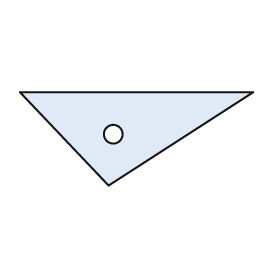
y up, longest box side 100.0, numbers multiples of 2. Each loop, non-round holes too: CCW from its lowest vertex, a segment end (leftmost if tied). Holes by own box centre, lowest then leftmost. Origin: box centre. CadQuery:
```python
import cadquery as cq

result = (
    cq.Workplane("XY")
    .moveTo(-12.0, -20.0)
    .lineTo(50.0, 20.0)
    .lineTo(-50.0, 20.0)
    .close()
    .moveTo(-10.0, 2.0)
    .circle(4.0)
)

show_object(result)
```